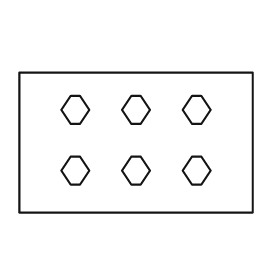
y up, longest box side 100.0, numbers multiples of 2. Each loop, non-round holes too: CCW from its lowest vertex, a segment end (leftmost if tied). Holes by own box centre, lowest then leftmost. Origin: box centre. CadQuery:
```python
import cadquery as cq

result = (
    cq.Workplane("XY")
    .moveTo(-50.0, -30.0)
    .lineTo(50.0, -30.0)
    .lineTo(50.0, 30.0)
    .lineTo(-50.0, 30.0)
    .close()
    .moveTo(-28.0, -18.0)
    .lineTo(-24.0, -18.0)
    .lineTo(-20.0, -12.0)
    .lineTo(-24.0, -6.0)
    .lineTo(-28.0, -6.0)
    .lineTo(-32.0, -12.0)
    .close()
    .moveTo(-2.0, -18.0)
    .lineTo(2.0, -18.0)
    .lineTo(6.0, -12.0)
    .lineTo(2.0, -6.0)
    .lineTo(-2.0, -6.0)
    .lineTo(-6.0, -12.0)
    .close()
    .moveTo(24.0, -18.0)
    .lineTo(28.0, -18.0)
    .lineTo(32.0, -12.0)
    .lineTo(28.0, -6.0)
    .lineTo(24.0, -6.0)
    .lineTo(20.0, -12.0)
    .close()
    .moveTo(-28.0, 8.0)
    .lineTo(-24.0, 8.0)
    .lineTo(-20.0, 14.0)
    .lineTo(-24.0, 20.0)
    .lineTo(-28.0, 20.0)
    .lineTo(-32.0, 14.0)
    .close()
    .moveTo(-2.0, 8.0)
    .lineTo(2.0, 8.0)
    .lineTo(6.0, 14.0)
    .lineTo(2.0, 20.0)
    .lineTo(-2.0, 20.0)
    .lineTo(-6.0, 14.0)
    .close()
    .moveTo(24.0, 8.0)
    .lineTo(28.0, 8.0)
    .lineTo(32.0, 14.0)
    .lineTo(28.0, 20.0)
    .lineTo(24.0, 20.0)
    .lineTo(20.0, 14.0)
    .close()
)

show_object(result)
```